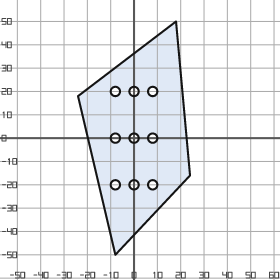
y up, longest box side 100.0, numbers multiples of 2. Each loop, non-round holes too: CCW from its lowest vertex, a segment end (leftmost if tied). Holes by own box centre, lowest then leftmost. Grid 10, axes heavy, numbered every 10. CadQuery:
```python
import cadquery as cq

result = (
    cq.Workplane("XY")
    .moveTo(-8.0, -50.0)
    .lineTo(24.0, -16.0)
    .lineTo(18.0, 50.0)
    .lineTo(-24.0, 18.0)
    .close()
    .moveTo(-8.0, -20.0)
    .circle(2.0)
    .moveTo(0.0, -20.0)
    .circle(2.0)
    .moveTo(8.0, -20.0)
    .circle(2.0)
    .moveTo(-8.0, 0.0)
    .circle(2.0)
    .moveTo(0.0, 0.0)
    .circle(2.0)
    .moveTo(8.0, 0.0)
    .circle(2.0)
    .moveTo(-8.0, 20.0)
    .circle(2.0)
    .moveTo(0.0, 20.0)
    .circle(2.0)
    .moveTo(8.0, 20.0)
    .circle(2.0)
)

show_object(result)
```